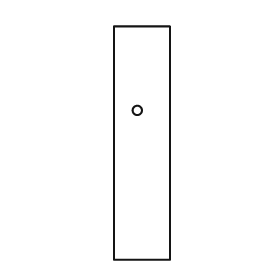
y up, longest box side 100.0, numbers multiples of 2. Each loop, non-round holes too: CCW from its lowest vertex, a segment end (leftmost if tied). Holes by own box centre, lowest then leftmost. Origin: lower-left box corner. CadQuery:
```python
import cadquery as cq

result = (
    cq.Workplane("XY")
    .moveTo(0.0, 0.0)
    .lineTo(24.0, 0.0)
    .lineTo(24.0, 100.0)
    .lineTo(0.0, 100.0)
    .close()
    .moveTo(10.0, 64.0)
    .circle(2.0)
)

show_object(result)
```